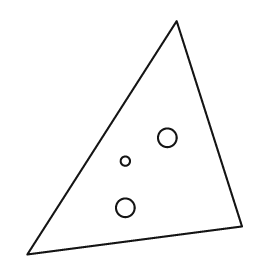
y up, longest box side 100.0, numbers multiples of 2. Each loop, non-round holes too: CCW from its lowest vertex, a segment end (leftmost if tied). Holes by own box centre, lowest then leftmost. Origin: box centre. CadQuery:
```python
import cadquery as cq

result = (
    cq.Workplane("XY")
    .moveTo(-46.0, -50.0)
    .lineTo(46.0, -38.0)
    .lineTo(18.0, 50.0)
    .close()
    .moveTo(-4.0, -30.0)
    .circle(4.0)
    .moveTo(-4.0, -10.0)
    .circle(2.0)
    .moveTo(14.0, 0.0)
    .circle(4.0)
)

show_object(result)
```